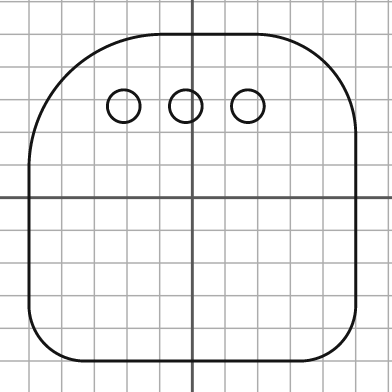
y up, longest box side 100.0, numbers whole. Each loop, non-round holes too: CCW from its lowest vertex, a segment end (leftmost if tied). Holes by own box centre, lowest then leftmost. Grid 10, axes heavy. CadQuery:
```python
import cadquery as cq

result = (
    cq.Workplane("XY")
    .moveTo(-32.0, -50.0)
    .lineTo(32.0, -50.0)
    .threePointArc((45.0, -45.0), (50.0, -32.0))
    .lineTo(50.0, 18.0)
    .threePointArc((41.0, 41.0), (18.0, 50.0))
    .lineTo(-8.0, 50.0)
    .threePointArc((-38.0, 38.0), (-50.0, 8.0))
    .lineTo(-50.0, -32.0)
    .threePointArc((-45.0, -45.0), (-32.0, -50.0))
    .close()
    .moveTo(-21.0, 28.0)
    .circle(5.0)
    .moveTo(-2.0, 28.0)
    .circle(5.0)
    .moveTo(17.0, 28.0)
    .circle(5.0)
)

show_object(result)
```